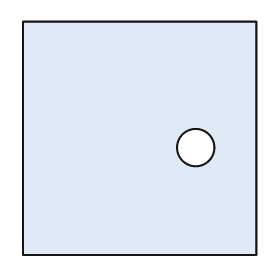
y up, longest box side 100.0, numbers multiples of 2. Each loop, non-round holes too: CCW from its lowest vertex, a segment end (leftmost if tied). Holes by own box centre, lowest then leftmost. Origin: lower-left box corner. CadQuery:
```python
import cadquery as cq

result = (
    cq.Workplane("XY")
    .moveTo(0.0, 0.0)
    .lineTo(100.0, 0.0)
    .lineTo(100.0, 100.0)
    .lineTo(0.0, 100.0)
    .close()
    .moveTo(74.0, 46.0)
    .circle(8.0)
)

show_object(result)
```